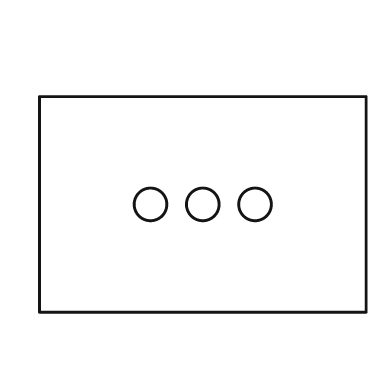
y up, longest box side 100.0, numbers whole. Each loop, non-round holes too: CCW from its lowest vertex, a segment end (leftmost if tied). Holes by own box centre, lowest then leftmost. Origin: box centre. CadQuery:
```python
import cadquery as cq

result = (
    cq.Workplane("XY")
    .moveTo(-50.0, -33.0)
    .lineTo(50.0, -33.0)
    .lineTo(50.0, 33.0)
    .lineTo(-50.0, 33.0)
    .close()
    .moveTo(-16.0, 0.0)
    .circle(5.0)
    .moveTo(0.0, 0.0)
    .circle(5.0)
    .moveTo(16.0, 0.0)
    .circle(5.0)
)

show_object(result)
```